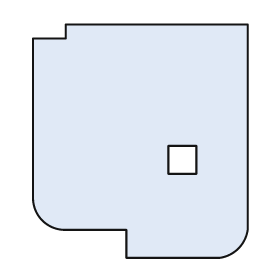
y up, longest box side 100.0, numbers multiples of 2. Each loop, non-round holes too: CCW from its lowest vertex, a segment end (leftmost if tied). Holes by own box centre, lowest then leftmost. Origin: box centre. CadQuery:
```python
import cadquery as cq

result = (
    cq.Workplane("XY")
    .moveTo(-6.0, -50.0)
    .lineTo(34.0, -50.0)
    .threePointArc((42.0, -46.0), (46.0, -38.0))
    .lineTo(46.0, 50.0)
    .lineTo(-32.0, 50.0)
    .lineTo(-32.0, 44.0)
    .lineTo(-46.0, 44.0)
    .lineTo(-46.0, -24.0)
    .threePointArc((-42.0, -34.0), (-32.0, -38.0))
    .lineTo(-6.0, -38.0)
    .close()
    .moveTo(12.0, -14.0)
    .lineTo(24.0, -14.0)
    .lineTo(24.0, -2.0)
    .lineTo(12.0, -2.0)
    .close()
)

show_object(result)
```